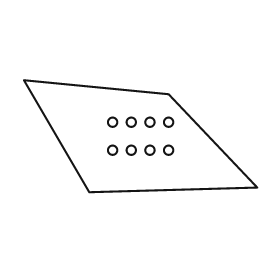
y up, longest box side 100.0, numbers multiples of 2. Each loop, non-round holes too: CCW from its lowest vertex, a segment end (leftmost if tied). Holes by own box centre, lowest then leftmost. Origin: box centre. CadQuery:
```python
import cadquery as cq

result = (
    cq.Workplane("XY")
    .moveTo(-22.0, -24.0)
    .lineTo(50.0, -22.0)
    .lineTo(12.0, 18.0)
    .lineTo(-50.0, 24.0)
    .close()
    .moveTo(-12.0, -6.0)
    .circle(2.0)
    .moveTo(-4.0, -6.0)
    .circle(2.0)
    .moveTo(4.0, -6.0)
    .circle(2.0)
    .moveTo(12.0, -6.0)
    .circle(2.0)
    .moveTo(-12.0, 6.0)
    .circle(2.0)
    .moveTo(-4.0, 6.0)
    .circle(2.0)
    .moveTo(4.0, 6.0)
    .circle(2.0)
    .moveTo(12.0, 6.0)
    .circle(2.0)
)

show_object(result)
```